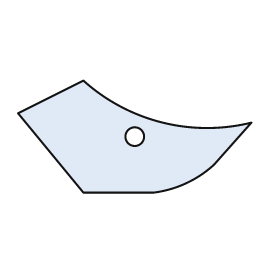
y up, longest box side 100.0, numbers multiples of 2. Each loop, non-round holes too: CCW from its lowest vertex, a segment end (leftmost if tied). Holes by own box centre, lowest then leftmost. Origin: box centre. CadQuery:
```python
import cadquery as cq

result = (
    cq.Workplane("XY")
    .moveTo(-22.0, -24.0)
    .lineTo(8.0, -24.0)
    .threePointArc((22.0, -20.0), (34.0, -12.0))
    .lineTo(50.0, 6.0)
    .threePointArc((12.0, 6.0), (-22.0, 24.0))
    .lineTo(-50.0, 10.0)
    .close()
    .moveTo(0.0, 0.0)
    .circle(4.0)
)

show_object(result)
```